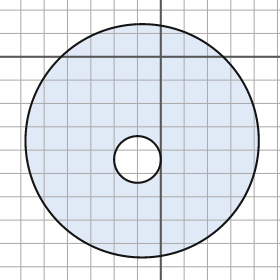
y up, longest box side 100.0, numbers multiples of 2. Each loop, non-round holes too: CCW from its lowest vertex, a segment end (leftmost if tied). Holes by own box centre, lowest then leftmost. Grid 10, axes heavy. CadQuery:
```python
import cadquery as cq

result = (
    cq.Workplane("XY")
    .moveTo(-8.0, -36.0)
    .circle(50.0)
    .moveTo(-10.0, -44.0)
    .circle(10.0)
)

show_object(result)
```